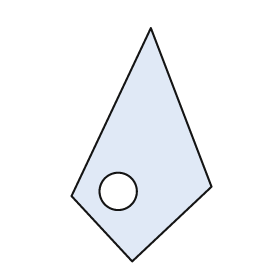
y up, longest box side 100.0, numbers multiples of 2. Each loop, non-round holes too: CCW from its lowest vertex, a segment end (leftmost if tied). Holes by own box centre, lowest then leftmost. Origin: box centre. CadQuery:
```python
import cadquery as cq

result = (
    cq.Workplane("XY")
    .moveTo(-4.0, -50.0)
    .lineTo(30.0, -18.0)
    .lineTo(4.0, 50.0)
    .lineTo(-30.0, -22.0)
    .close()
    .moveTo(-10.0, -20.0)
    .circle(8.0)
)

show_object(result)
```